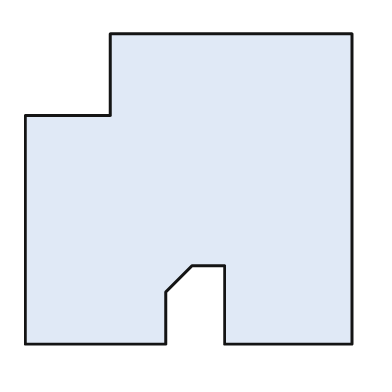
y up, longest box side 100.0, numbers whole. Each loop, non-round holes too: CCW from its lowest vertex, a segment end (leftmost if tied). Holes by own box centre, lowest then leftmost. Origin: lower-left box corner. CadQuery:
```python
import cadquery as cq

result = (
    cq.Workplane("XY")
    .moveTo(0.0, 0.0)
    .lineTo(43.0, 0.0)
    .lineTo(43.0, 16.0)
    .lineTo(51.0, 24.0)
    .lineTo(61.0, 24.0)
    .lineTo(61.0, 0.0)
    .lineTo(100.0, 0.0)
    .lineTo(100.0, 95.0)
    .lineTo(26.0, 95.0)
    .lineTo(26.0, 70.0)
    .lineTo(0.0, 70.0)
    .close()
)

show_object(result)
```